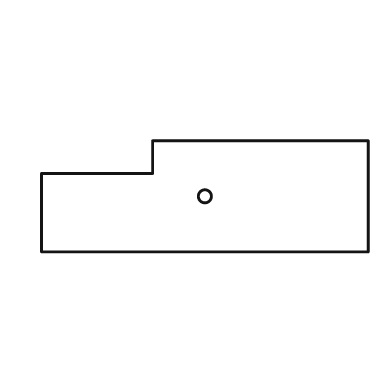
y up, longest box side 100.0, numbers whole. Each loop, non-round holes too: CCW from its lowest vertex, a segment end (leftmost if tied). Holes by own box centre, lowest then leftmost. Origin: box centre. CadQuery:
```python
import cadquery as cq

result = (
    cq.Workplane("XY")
    .moveTo(-50.0, -17.0)
    .lineTo(50.0, -17.0)
    .lineTo(50.0, 17.0)
    .lineTo(-16.0, 17.0)
    .lineTo(-16.0, 7.0)
    .lineTo(-50.0, 7.0)
    .close()
    .moveTo(0.0, 0.0)
    .circle(2.0)
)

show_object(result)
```